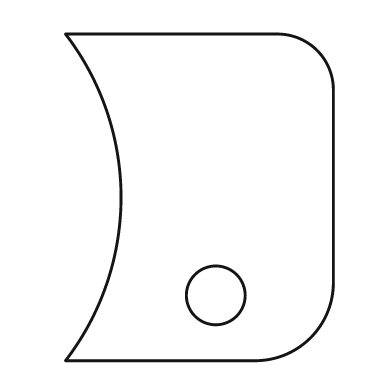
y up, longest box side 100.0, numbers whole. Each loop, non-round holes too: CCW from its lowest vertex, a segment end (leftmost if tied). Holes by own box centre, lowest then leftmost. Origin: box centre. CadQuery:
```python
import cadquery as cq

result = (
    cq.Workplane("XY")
    .moveTo(-41.0, -50.0)
    .lineTo(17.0, -50.0)
    .threePointArc((34.0, -43.0), (41.0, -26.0))
    .lineTo(41.0, 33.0)
    .threePointArc((36.0, 45.0), (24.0, 50.0))
    .lineTo(-41.0, 50.0)
    .threePointArc((-24.0, 0.0), (-41.0, -50.0))
    .close()
    .moveTo(5.0, -30.0)
    .circle(9.0)
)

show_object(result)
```